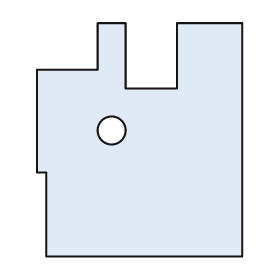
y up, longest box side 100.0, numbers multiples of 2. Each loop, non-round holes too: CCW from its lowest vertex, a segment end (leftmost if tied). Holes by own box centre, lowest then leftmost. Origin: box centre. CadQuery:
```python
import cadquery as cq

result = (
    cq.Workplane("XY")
    .moveTo(-40.0, -50.0)
    .lineTo(44.0, -50.0)
    .lineTo(44.0, 50.0)
    .lineTo(16.0, 50.0)
    .lineTo(16.0, 22.0)
    .lineTo(-6.0, 22.0)
    .lineTo(-6.0, 50.0)
    .lineTo(-18.0, 50.0)
    .lineTo(-18.0, 30.0)
    .lineTo(-44.0, 30.0)
    .lineTo(-44.0, -14.0)
    .lineTo(-40.0, -14.0)
    .close()
    .moveTo(-12.0, 4.0)
    .circle(6.0)
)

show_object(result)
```